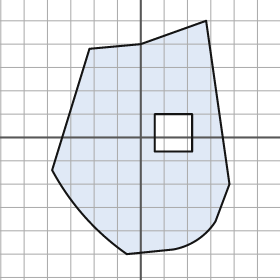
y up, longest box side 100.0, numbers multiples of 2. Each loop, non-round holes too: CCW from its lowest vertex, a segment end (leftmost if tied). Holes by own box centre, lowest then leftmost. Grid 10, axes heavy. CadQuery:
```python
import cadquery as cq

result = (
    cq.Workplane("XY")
    .moveTo(-6.0, -50.0)
    .lineTo(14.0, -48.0)
    .threePointArc((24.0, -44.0), (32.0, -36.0))
    .lineTo(38.0, -20.0)
    .lineTo(28.0, 50.0)
    .lineTo(0.0, 40.0)
    .lineTo(-22.0, 38.0)
    .lineTo(-38.0, -14.0)
    .threePointArc((-24.0, -34.0), (-6.0, -50.0))
    .close()
    .moveTo(6.0, -6.0)
    .lineTo(22.0, -6.0)
    .lineTo(22.0, 10.0)
    .lineTo(6.0, 10.0)
    .close()
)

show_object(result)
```